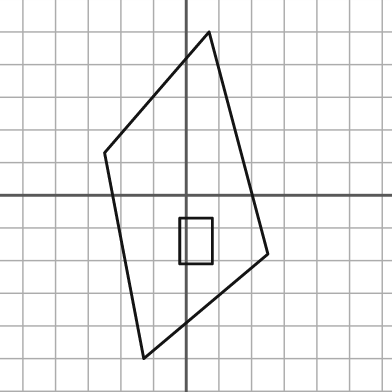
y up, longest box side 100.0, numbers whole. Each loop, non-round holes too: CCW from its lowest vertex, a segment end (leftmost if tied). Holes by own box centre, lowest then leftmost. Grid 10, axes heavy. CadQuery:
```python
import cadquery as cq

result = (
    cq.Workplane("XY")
    .moveTo(-13.0, -50.0)
    .lineTo(25.0, -18.0)
    .lineTo(7.0, 50.0)
    .lineTo(-25.0, 13.0)
    .close()
    .moveTo(-2.0, -21.0)
    .lineTo(8.0, -21.0)
    .lineTo(8.0, -7.0)
    .lineTo(-2.0, -7.0)
    .close()
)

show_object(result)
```